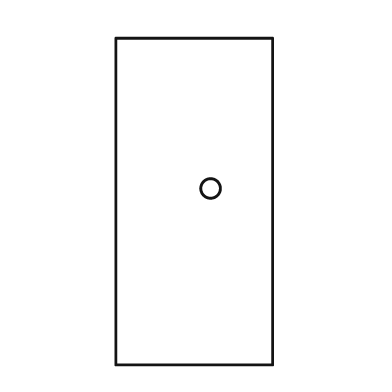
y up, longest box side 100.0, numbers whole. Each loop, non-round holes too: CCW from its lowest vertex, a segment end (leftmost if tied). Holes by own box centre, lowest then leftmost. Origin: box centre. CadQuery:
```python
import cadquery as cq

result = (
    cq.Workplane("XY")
    .moveTo(-24.0, -50.0)
    .lineTo(24.0, -50.0)
    .lineTo(24.0, 50.0)
    .lineTo(-24.0, 50.0)
    .close()
    .moveTo(5.0, 4.0)
    .circle(3.0)
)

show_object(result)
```